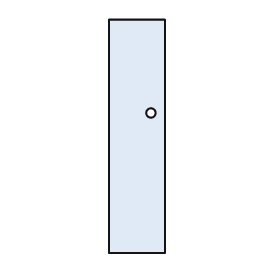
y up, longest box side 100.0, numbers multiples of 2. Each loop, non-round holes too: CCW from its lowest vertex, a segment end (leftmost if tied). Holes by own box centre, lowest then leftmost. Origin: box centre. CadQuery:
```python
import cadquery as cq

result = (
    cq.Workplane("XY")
    .moveTo(-12.0, -50.0)
    .lineTo(12.0, -50.0)
    .lineTo(12.0, 50.0)
    .lineTo(-12.0, 50.0)
    .close()
    .moveTo(6.0, 10.0)
    .circle(2.0)
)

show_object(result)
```